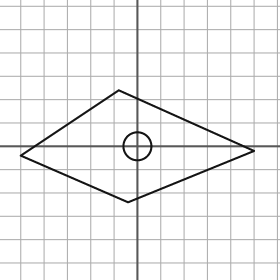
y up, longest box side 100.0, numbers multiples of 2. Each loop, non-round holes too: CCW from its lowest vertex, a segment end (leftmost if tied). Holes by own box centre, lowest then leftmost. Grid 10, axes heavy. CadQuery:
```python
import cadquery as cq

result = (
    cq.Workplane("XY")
    .moveTo(-4.0, -24.0)
    .lineTo(50.0, -2.0)
    .lineTo(-8.0, 24.0)
    .lineTo(-50.0, -4.0)
    .close()
    .moveTo(0.0, 0.0)
    .circle(6.0)
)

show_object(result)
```